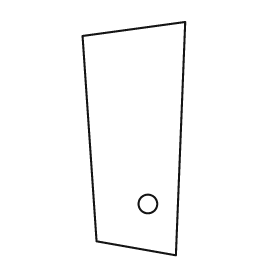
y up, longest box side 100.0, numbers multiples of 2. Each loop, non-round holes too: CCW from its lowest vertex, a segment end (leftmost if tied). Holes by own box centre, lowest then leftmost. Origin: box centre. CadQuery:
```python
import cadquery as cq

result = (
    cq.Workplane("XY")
    .moveTo(18.0, -50.0)
    .lineTo(22.0, 50.0)
    .lineTo(-22.0, 44.0)
    .lineTo(-16.0, -44.0)
    .close()
    .moveTo(6.0, -28.0)
    .circle(4.0)
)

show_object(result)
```